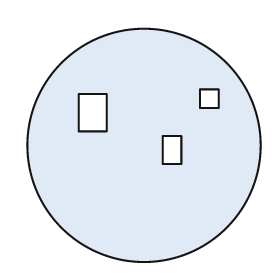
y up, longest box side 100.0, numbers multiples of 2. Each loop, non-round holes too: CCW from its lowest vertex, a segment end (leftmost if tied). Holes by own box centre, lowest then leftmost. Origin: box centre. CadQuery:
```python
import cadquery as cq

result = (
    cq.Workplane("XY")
    .moveTo(0.0, 0.0)
    .circle(50.0)
    .moveTo(8.0, -8.0)
    .lineTo(16.0, -8.0)
    .lineTo(16.0, 4.0)
    .lineTo(8.0, 4.0)
    .close()
    .moveTo(-28.0, 6.0)
    .lineTo(-16.0, 6.0)
    .lineTo(-16.0, 22.0)
    .lineTo(-28.0, 22.0)
    .close()
    .moveTo(24.0, 16.0)
    .lineTo(32.0, 16.0)
    .lineTo(32.0, 24.0)
    .lineTo(24.0, 24.0)
    .close()
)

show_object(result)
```